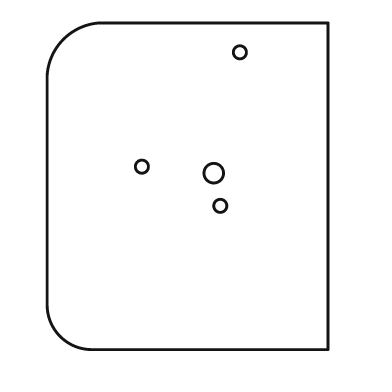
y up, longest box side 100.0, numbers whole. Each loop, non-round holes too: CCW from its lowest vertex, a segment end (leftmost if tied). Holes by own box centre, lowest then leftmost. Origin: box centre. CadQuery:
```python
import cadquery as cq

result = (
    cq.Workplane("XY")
    .moveTo(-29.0, -50.0)
    .lineTo(43.0, -50.0)
    .lineTo(43.0, 50.0)
    .lineTo(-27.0, 50.0)
    .threePointArc((-38.0, 45.0), (-43.0, 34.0))
    .lineTo(-43.0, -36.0)
    .threePointArc((-39.0, -46.0), (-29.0, -50.0))
    .close()
    .moveTo(10.0, -6.0)
    .circle(2.0)
    .moveTo(8.0, 4.0)
    .circle(3.0)
    .moveTo(-14.0, 6.0)
    .circle(2.0)
    .moveTo(16.0, 41.0)
    .circle(2.0)
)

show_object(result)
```